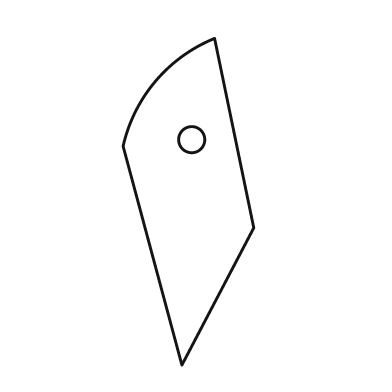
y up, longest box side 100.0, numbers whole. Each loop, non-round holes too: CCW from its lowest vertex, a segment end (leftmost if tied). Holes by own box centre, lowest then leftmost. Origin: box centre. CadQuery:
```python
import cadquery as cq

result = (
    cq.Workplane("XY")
    .moveTo(-2.0, -50.0)
    .lineTo(20.0, -8.0)
    .lineTo(8.0, 50.0)
    .threePointArc((-10.0, 37.0), (-20.0, 17.0))
    .close()
    .moveTo(1.0, 19.0)
    .circle(4.0)
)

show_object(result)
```